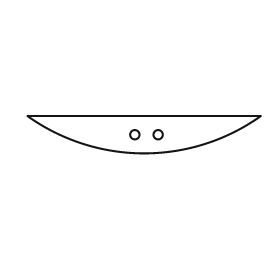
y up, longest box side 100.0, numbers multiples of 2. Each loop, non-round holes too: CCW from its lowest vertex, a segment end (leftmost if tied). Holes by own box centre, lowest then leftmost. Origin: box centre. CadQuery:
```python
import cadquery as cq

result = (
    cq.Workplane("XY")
    .moveTo(-50.0, 8.0)
    .threePointArc((0.0, -8.0), (50.0, 8.0))
    .close()
    .moveTo(-4.0, 0.0)
    .circle(2.0)
    .moveTo(6.0, 0.0)
    .circle(2.0)
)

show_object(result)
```